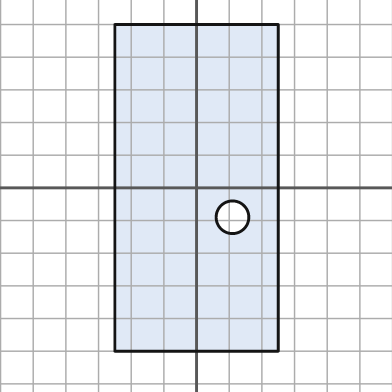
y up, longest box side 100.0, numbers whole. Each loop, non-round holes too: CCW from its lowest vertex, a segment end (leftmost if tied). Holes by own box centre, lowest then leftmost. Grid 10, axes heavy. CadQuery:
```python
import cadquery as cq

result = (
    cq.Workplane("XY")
    .moveTo(-25.0, -50.0)
    .lineTo(25.0, -50.0)
    .lineTo(25.0, 50.0)
    .lineTo(-25.0, 50.0)
    .close()
    .moveTo(11.0, -9.0)
    .circle(5.0)
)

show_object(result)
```